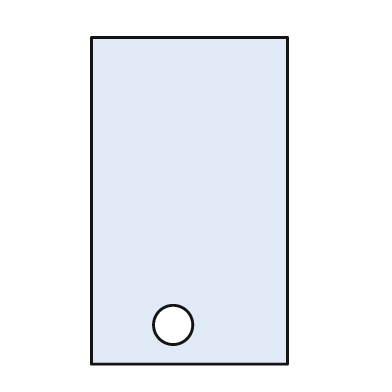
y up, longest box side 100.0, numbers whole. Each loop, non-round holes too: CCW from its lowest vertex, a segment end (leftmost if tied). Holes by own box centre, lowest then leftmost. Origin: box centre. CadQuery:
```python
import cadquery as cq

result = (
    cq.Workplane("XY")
    .moveTo(-30.0, -50.0)
    .lineTo(30.0, -50.0)
    .lineTo(30.0, 50.0)
    .lineTo(-30.0, 50.0)
    .close()
    .moveTo(-5.0, -38.0)
    .circle(6.0)
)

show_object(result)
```